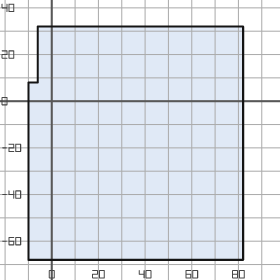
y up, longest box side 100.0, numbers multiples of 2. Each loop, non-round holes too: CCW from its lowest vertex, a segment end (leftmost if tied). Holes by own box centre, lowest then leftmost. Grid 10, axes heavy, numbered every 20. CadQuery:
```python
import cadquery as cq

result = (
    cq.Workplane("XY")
    .moveTo(-10.0, -68.0)
    .lineTo(82.0, -68.0)
    .lineTo(82.0, 32.0)
    .lineTo(-6.0, 32.0)
    .lineTo(-6.0, 8.0)
    .lineTo(-10.0, 8.0)
    .close()
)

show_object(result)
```